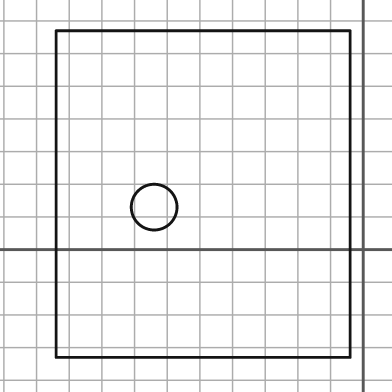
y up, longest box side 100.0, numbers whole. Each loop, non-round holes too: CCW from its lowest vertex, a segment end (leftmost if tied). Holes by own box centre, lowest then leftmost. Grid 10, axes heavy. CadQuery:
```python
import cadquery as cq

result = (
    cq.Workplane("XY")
    .moveTo(-94.0, -33.0)
    .lineTo(-4.0, -33.0)
    .lineTo(-4.0, 67.0)
    .lineTo(-94.0, 67.0)
    .close()
    .moveTo(-64.0, 13.0)
    .circle(7.0)
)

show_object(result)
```